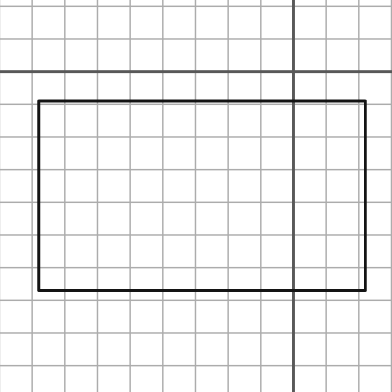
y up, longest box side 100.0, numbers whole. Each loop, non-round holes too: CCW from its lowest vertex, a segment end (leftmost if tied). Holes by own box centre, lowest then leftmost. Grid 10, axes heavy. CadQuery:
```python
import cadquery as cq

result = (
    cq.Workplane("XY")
    .moveTo(-78.0, -67.0)
    .lineTo(22.0, -67.0)
    .lineTo(22.0, -9.0)
    .lineTo(-78.0, -9.0)
    .close()
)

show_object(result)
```